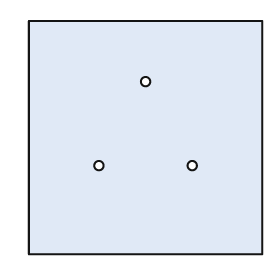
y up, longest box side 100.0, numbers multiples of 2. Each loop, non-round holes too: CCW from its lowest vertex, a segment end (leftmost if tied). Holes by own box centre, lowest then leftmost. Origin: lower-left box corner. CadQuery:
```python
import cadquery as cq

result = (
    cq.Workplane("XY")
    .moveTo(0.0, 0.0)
    .lineTo(100.0, 0.0)
    .lineTo(100.0, 100.0)
    .lineTo(0.0, 100.0)
    .close()
    .moveTo(30.0, 38.0)
    .circle(2.0)
    .moveTo(70.0, 38.0)
    .circle(2.0)
    .moveTo(50.0, 74.0)
    .circle(2.0)
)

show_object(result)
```